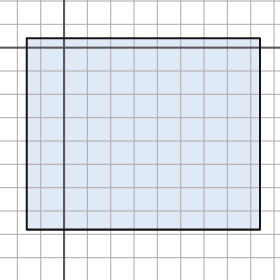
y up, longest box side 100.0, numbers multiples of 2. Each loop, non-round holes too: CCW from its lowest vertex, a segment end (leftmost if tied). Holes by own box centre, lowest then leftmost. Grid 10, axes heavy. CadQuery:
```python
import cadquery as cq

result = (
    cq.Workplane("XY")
    .moveTo(-16.0, -78.0)
    .lineTo(84.0, -78.0)
    .lineTo(84.0, 4.0)
    .lineTo(-16.0, 4.0)
    .close()
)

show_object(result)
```